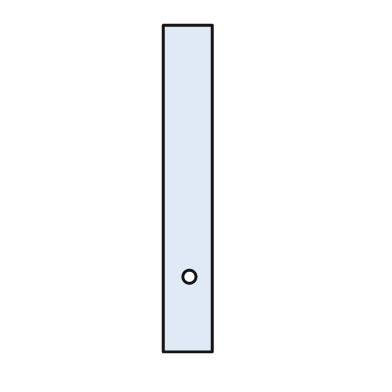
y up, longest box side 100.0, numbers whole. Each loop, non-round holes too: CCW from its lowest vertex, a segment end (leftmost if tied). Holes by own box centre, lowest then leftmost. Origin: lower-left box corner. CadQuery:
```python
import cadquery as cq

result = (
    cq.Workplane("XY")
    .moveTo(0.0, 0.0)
    .lineTo(15.0, 0.0)
    .lineTo(15.0, 100.0)
    .lineTo(0.0, 100.0)
    .close()
    .moveTo(8.0, 23.0)
    .circle(2.0)
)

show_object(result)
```